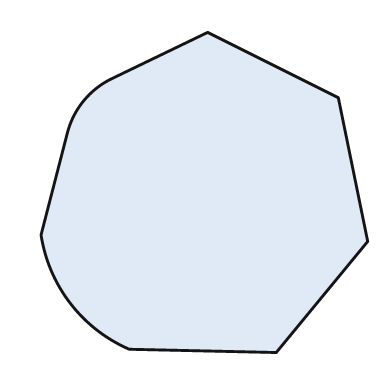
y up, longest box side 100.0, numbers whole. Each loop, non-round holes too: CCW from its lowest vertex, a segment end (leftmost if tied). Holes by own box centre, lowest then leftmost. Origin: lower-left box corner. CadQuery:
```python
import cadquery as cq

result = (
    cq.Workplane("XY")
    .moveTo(72.0, 0.0)
    .lineTo(100.0, 34.0)
    .lineTo(91.0, 78.0)
    .lineTo(51.0, 98.0)
    .lineTo(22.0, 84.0)
    .threePointArc((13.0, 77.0), (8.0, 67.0))
    .lineTo(0.0, 36.0)
    .threePointArc((9.0, 15.0), (27.0, 1.0))
    .close()
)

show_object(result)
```